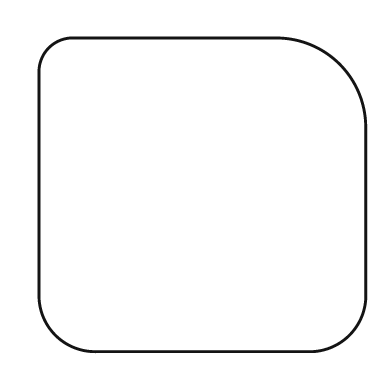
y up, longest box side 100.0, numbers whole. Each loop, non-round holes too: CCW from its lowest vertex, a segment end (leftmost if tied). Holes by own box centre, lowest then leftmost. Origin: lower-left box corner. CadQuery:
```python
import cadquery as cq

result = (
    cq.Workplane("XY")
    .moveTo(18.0, 0.0)
    .lineTo(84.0, 0.0)
    .threePointArc((95.0, 5.0), (100.0, 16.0))
    .lineTo(100.0, 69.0)
    .threePointArc((92.0, 88.0), (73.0, 96.0))
    .lineTo(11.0, 96.0)
    .threePointArc((3.0, 93.0), (0.0, 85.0))
    .lineTo(0.0, 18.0)
    .threePointArc((5.0, 5.0), (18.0, 0.0))
    .close()
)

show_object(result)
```